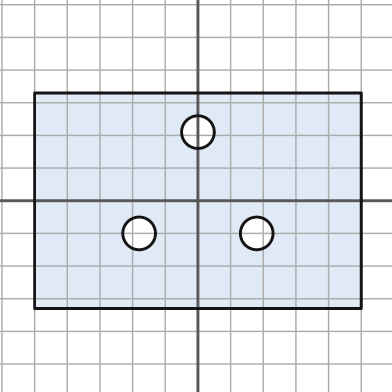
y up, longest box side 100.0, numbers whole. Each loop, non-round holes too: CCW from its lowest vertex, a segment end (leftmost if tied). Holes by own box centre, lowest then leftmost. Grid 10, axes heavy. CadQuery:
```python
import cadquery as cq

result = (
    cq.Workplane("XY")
    .moveTo(-50.0, -33.0)
    .lineTo(50.0, -33.0)
    .lineTo(50.0, 33.0)
    .lineTo(-50.0, 33.0)
    .close()
    .moveTo(-18.0, -10.0)
    .circle(5.0)
    .moveTo(18.0, -10.0)
    .circle(5.0)
    .moveTo(0.0, 21.0)
    .circle(5.0)
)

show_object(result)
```